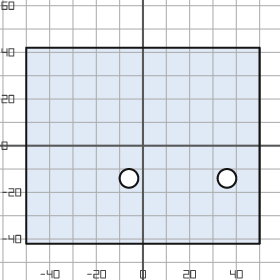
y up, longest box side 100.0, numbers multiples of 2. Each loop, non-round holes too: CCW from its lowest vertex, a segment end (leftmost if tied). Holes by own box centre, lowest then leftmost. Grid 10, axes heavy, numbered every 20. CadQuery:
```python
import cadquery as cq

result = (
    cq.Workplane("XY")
    .moveTo(-50.0, -42.0)
    .lineTo(50.0, -42.0)
    .lineTo(50.0, 42.0)
    .lineTo(-50.0, 42.0)
    .close()
    .moveTo(-6.0, -14.0)
    .circle(4.0)
    .moveTo(36.0, -14.0)
    .circle(4.0)
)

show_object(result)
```